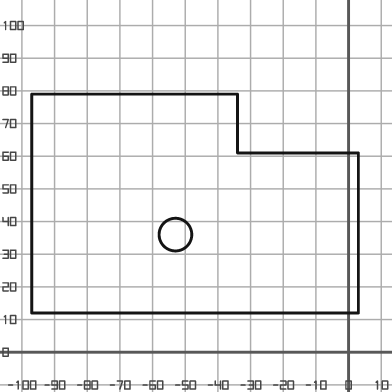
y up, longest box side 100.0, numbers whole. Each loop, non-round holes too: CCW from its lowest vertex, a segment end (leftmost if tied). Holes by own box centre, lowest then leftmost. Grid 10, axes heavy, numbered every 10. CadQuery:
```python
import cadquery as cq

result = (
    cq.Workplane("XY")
    .moveTo(-97.0, 12.0)
    .lineTo(3.0, 12.0)
    .lineTo(3.0, 61.0)
    .lineTo(-34.0, 61.0)
    .lineTo(-34.0, 79.0)
    .lineTo(-97.0, 79.0)
    .close()
    .moveTo(-53.0, 36.0)
    .circle(5.0)
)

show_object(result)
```